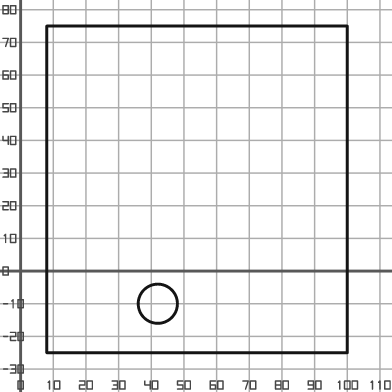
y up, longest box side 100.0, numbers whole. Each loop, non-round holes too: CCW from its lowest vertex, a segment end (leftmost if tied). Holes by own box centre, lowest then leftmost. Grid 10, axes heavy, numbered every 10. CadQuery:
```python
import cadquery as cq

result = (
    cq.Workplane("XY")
    .moveTo(8.0, -25.0)
    .lineTo(100.0, -25.0)
    .lineTo(100.0, 75.0)
    .lineTo(8.0, 75.0)
    .close()
    .moveTo(42.0, -10.0)
    .circle(6.0)
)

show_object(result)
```